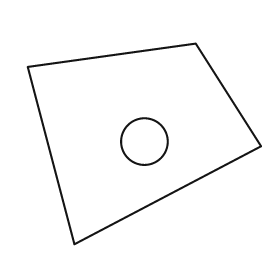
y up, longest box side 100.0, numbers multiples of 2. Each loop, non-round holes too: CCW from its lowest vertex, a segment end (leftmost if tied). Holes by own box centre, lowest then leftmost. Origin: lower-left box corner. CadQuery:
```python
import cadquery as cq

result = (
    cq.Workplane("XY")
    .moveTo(20.0, 0.0)
    .lineTo(100.0, 42.0)
    .lineTo(72.0, 86.0)
    .lineTo(0.0, 76.0)
    .close()
    .moveTo(50.0, 44.0)
    .circle(10.0)
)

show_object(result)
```